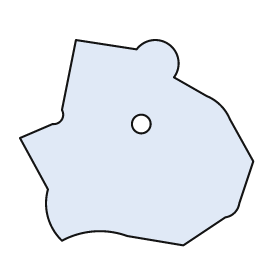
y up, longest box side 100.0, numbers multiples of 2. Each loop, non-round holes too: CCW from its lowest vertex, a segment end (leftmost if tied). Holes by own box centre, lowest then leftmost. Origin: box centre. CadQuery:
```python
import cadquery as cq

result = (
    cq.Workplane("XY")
    .moveTo(20.0, -44.0)
    .lineTo(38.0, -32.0)
    .threePointArc((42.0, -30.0), (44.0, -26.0))
    .lineTo(50.0, -8.0)
    .lineTo(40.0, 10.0)
    .threePointArc((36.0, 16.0), (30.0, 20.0))
    .lineTo(16.0, 28.0)
    .threePointArc((14.0, 42.0), (0.0, 40.0))
    .lineTo(-26.0, 44.0)
    .lineTo(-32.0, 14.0)
    .threePointArc((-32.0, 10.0), (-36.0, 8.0))
    .lineTo(-50.0, 2.0)
    .lineTo(-38.0, -20.0)
    .threePointArc((-38.0, -32.0), (-32.0, -42.0))
    .threePointArc((-18.0, -38.0), (-4.0, -40.0))
    .close()
    .moveTo(2.0, 8.0)
    .circle(4.0)
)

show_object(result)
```